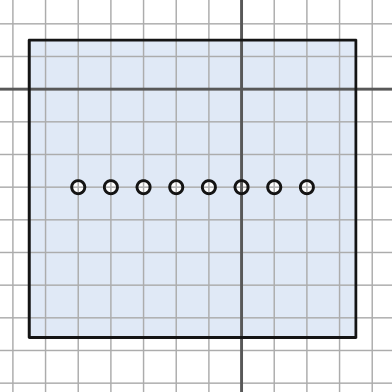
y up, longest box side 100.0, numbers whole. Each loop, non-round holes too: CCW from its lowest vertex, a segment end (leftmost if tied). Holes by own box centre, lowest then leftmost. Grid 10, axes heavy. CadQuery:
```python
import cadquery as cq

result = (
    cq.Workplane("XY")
    .moveTo(-65.0, -76.0)
    .lineTo(35.0, -76.0)
    .lineTo(35.0, 15.0)
    .lineTo(-65.0, 15.0)
    .close()
    .moveTo(-50.0, -30.0)
    .circle(2.0)
    .moveTo(-40.0, -30.0)
    .circle(2.0)
    .moveTo(-30.0, -30.0)
    .circle(2.0)
    .moveTo(-20.0, -30.0)
    .circle(2.0)
    .moveTo(-10.0, -30.0)
    .circle(2.0)
    .moveTo(0.0, -30.0)
    .circle(2.0)
    .moveTo(10.0, -30.0)
    .circle(2.0)
    .moveTo(20.0, -30.0)
    .circle(2.0)
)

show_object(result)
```